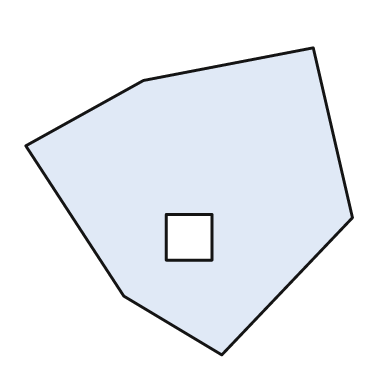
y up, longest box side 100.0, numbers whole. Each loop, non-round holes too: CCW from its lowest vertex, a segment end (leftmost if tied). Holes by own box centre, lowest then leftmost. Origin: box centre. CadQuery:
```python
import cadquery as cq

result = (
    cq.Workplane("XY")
    .moveTo(10.0, -47.0)
    .lineTo(50.0, -5.0)
    .lineTo(38.0, 47.0)
    .lineTo(-14.0, 37.0)
    .lineTo(-50.0, 17.0)
    .lineTo(-20.0, -29.0)
    .close()
    .moveTo(-7.0, -18.0)
    .lineTo(7.0, -18.0)
    .lineTo(7.0, -4.0)
    .lineTo(-7.0, -4.0)
    .close()
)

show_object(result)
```